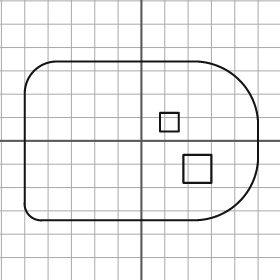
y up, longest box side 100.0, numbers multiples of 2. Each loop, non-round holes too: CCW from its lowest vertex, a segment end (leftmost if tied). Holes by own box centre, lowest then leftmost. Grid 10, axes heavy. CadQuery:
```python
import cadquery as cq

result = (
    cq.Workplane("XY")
    .moveTo(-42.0, -34.0)
    .lineTo(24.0, -34.0)
    .threePointArc((42.0, -26.0), (50.0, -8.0))
    .lineTo(50.0, 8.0)
    .threePointArc((42.0, 26.0), (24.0, 34.0))
    .lineTo(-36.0, 34.0)
    .threePointArc((-46.0, 30.0), (-50.0, 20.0))
    .lineTo(-50.0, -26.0)
    .threePointArc((-48.0, -32.0), (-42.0, -34.0))
    .close()
    .moveTo(18.0, -18.0)
    .lineTo(30.0, -18.0)
    .lineTo(30.0, -6.0)
    .lineTo(18.0, -6.0)
    .close()
    .moveTo(8.0, 4.0)
    .lineTo(16.0, 4.0)
    .lineTo(16.0, 12.0)
    .lineTo(8.0, 12.0)
    .close()
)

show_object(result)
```